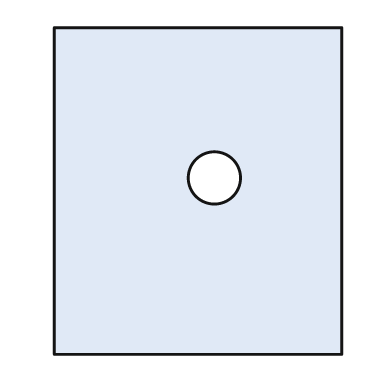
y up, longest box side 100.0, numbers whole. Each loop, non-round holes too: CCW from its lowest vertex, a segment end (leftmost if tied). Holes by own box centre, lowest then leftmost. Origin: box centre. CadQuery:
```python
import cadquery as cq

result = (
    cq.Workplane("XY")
    .moveTo(-44.0, -50.0)
    .lineTo(44.0, -50.0)
    .lineTo(44.0, 50.0)
    .lineTo(-44.0, 50.0)
    .close()
    .moveTo(5.0, 4.0)
    .circle(8.0)
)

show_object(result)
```